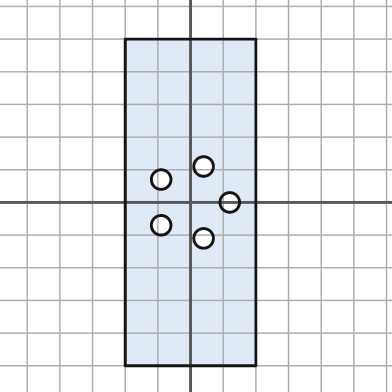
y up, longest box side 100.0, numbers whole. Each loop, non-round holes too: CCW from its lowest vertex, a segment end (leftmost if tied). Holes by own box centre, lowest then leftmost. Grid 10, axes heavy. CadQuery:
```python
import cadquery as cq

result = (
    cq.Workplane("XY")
    .moveTo(-20.0, -50.0)
    .lineTo(20.0, -50.0)
    .lineTo(20.0, 50.0)
    .lineTo(-20.0, 50.0)
    .close()
    .moveTo(4.0, -11.0)
    .circle(3.0)
    .moveTo(-9.0, -7.0)
    .circle(3.0)
    .moveTo(12.0, 0.0)
    .circle(3.0)
    .moveTo(-9.0, 7.0)
    .circle(3.0)
    .moveTo(4.0, 11.0)
    .circle(3.0)
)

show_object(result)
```